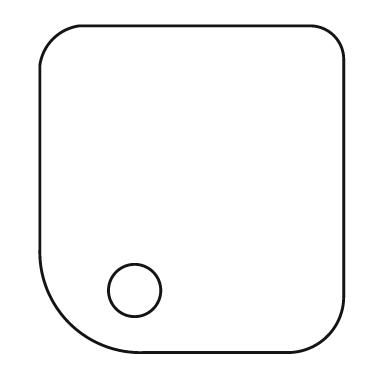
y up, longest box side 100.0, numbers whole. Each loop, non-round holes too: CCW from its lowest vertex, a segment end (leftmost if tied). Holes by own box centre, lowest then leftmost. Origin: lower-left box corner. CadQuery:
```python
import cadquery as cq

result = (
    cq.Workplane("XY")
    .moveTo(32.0, 0.0)
    .lineTo(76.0, 0.0)
    .threePointArc((88.0, 5.0), (93.0, 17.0))
    .lineTo(93.0, 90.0)
    .threePointArc((90.0, 97.0), (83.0, 100.0))
    .lineTo(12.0, 100.0)
    .threePointArc((4.0, 96.0), (0.0, 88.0))
    .lineTo(0.0, 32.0)
    .threePointArc((9.0, 9.0), (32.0, 0.0))
    .close()
    .moveTo(29.0, 19.0)
    .circle(8.0)
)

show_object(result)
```